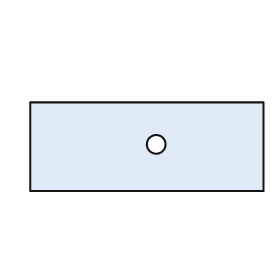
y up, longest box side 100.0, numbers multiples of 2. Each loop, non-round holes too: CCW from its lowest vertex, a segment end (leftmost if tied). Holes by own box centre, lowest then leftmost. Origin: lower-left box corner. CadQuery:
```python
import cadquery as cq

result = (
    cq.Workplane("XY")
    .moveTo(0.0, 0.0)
    .lineTo(100.0, 0.0)
    .lineTo(100.0, 38.0)
    .lineTo(0.0, 38.0)
    .close()
    .moveTo(54.0, 20.0)
    .circle(4.0)
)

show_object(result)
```